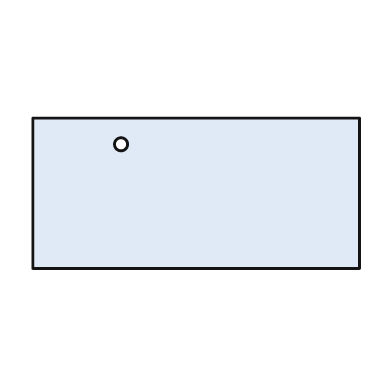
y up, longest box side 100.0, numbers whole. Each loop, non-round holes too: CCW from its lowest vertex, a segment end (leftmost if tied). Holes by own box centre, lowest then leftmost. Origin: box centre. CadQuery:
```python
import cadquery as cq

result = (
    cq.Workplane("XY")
    .moveTo(-50.0, -23.0)
    .lineTo(50.0, -23.0)
    .lineTo(50.0, 23.0)
    .lineTo(-50.0, 23.0)
    .close()
    .moveTo(-23.0, 15.0)
    .circle(2.0)
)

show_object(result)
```